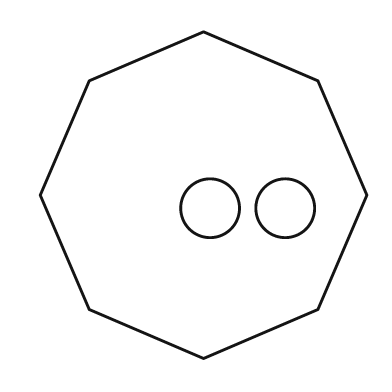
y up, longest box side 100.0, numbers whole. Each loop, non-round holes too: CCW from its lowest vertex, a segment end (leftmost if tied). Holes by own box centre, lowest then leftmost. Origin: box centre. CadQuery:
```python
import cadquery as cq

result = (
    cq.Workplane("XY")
    .moveTo(0.0, -50.0)
    .lineTo(35.0, -35.0)
    .lineTo(50.0, 0.0)
    .lineTo(35.0, 35.0)
    .lineTo(0.0, 50.0)
    .lineTo(-35.0, 35.0)
    .lineTo(-50.0, 0.0)
    .lineTo(-35.0, -35.0)
    .close()
    .moveTo(2.0, -4.0)
    .circle(9.0)
    .moveTo(25.0, -4.0)
    .circle(9.0)
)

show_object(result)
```